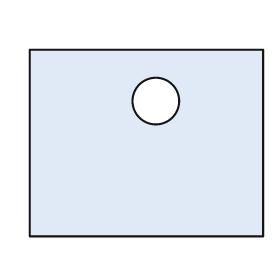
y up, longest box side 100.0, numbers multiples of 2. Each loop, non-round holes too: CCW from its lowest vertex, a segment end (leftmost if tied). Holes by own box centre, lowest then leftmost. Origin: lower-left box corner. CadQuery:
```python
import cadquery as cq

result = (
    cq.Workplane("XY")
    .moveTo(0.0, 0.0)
    .lineTo(100.0, 0.0)
    .lineTo(100.0, 80.0)
    .lineTo(0.0, 80.0)
    .close()
    .moveTo(54.0, 58.0)
    .circle(10.0)
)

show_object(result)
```